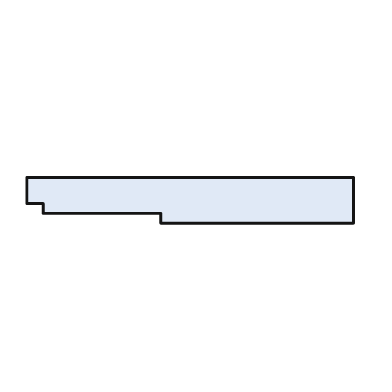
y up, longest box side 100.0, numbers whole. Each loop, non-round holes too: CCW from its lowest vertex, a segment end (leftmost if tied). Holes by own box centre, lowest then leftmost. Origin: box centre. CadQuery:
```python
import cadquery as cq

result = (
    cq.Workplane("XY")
    .moveTo(-9.0, -7.0)
    .lineTo(50.0, -7.0)
    .lineTo(50.0, 7.0)
    .lineTo(-50.0, 7.0)
    .lineTo(-50.0, -1.0)
    .lineTo(-45.0, -1.0)
    .lineTo(-45.0, -4.0)
    .lineTo(-9.0, -4.0)
    .close()
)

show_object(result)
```